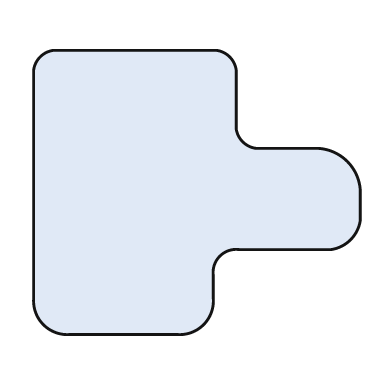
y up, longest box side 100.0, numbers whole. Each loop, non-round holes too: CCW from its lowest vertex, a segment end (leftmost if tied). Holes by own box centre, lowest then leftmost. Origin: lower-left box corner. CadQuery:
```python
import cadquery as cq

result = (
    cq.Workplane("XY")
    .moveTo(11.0, 0.0)
    .lineTo(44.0, 0.0)
    .threePointArc((52.0, 3.0), (55.0, 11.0))
    .lineTo(55.0, 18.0)
    .threePointArc((57.0, 24.0), (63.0, 26.0))
    .lineTo(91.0, 26.0)
    .threePointArc((97.0, 29.0), (100.0, 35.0))
    .lineTo(100.0, 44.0)
    .threePointArc((96.0, 53.0), (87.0, 57.0))
    .lineTo(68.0, 57.0)
    .threePointArc((64.0, 59.0), (62.0, 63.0))
    .lineTo(62.0, 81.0)
    .threePointArc((60.0, 85.0), (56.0, 87.0))
    .lineTo(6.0, 87.0)
    .threePointArc((2.0, 85.0), (0.0, 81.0))
    .lineTo(0.0, 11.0)
    .threePointArc((3.0, 3.0), (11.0, 0.0))
    .close()
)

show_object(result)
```